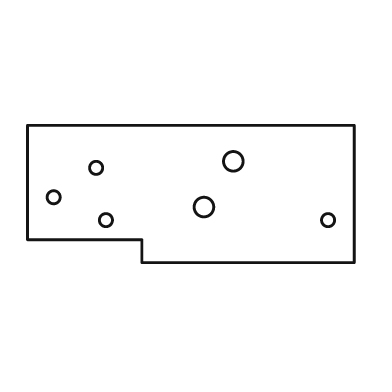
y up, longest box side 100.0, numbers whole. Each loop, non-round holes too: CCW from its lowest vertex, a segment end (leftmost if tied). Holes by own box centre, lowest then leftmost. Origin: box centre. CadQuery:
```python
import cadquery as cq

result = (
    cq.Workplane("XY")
    .moveTo(-15.0, -21.0)
    .lineTo(50.0, -21.0)
    .lineTo(50.0, 21.0)
    .lineTo(-50.0, 21.0)
    .lineTo(-50.0, -14.0)
    .lineTo(-15.0, -14.0)
    .close()
    .moveTo(-26.0, -8.0)
    .circle(2.0)
    .moveTo(42.0, -8.0)
    .circle(2.0)
    .moveTo(4.0, -4.0)
    .circle(3.0)
    .moveTo(-42.0, -1.0)
    .circle(2.0)
    .moveTo(-29.0, 8.0)
    .circle(2.0)
    .moveTo(13.0, 10.0)
    .circle(3.0)
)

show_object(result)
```